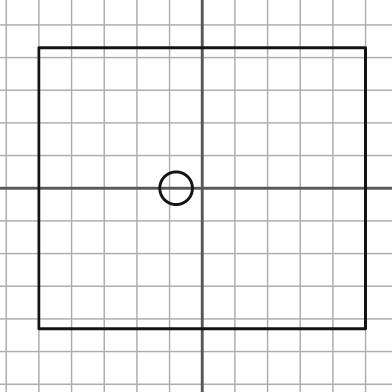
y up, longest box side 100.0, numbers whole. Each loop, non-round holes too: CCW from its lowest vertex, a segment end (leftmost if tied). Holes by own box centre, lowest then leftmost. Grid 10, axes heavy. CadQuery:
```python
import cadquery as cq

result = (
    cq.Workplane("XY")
    .moveTo(-50.0, -43.0)
    .lineTo(50.0, -43.0)
    .lineTo(50.0, 43.0)
    .lineTo(-50.0, 43.0)
    .close()
    .moveTo(-8.0, 0.0)
    .circle(5.0)
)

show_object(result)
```